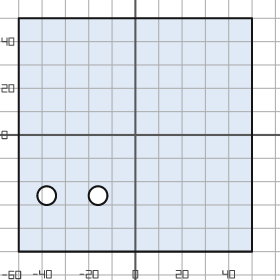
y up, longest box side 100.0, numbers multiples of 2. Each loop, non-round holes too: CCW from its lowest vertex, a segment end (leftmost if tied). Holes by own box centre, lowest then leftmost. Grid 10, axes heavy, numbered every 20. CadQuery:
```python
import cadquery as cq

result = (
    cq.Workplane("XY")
    .moveTo(-50.0, -50.0)
    .lineTo(50.0, -50.0)
    .lineTo(50.0, 50.0)
    .lineTo(-50.0, 50.0)
    .close()
    .moveTo(-38.0, -26.0)
    .circle(4.0)
    .moveTo(-16.0, -26.0)
    .circle(4.0)
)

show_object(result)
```